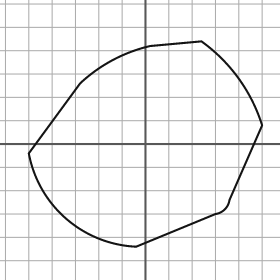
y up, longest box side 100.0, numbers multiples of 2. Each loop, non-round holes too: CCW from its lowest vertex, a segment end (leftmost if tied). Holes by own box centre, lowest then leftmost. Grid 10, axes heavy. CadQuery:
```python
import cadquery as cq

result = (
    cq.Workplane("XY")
    .moveTo(-4.0, -44.0)
    .lineTo(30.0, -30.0)
    .threePointArc((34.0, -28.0), (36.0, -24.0))
    .lineTo(50.0, 8.0)
    .threePointArc((40.0, 28.0), (24.0, 44.0))
    .lineTo(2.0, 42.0)
    .threePointArc((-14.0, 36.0), (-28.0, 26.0))
    .lineTo(-50.0, -4.0)
    .threePointArc((-34.0, -32.0), (-4.0, -44.0))
    .close()
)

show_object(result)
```